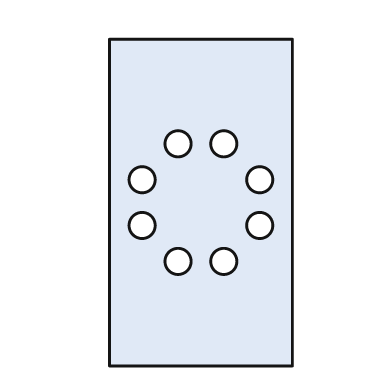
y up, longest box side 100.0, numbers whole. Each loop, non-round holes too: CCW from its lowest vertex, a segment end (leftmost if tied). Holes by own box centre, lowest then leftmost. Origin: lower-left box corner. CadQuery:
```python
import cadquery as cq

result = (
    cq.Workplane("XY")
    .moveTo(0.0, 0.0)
    .lineTo(56.0, 0.0)
    .lineTo(56.0, 100.0)
    .lineTo(0.0, 100.0)
    .close()
    .moveTo(21.0, 32.0)
    .circle(4.0)
    .moveTo(35.0, 32.0)
    .circle(4.0)
    .moveTo(10.0, 43.0)
    .circle(4.0)
    .moveTo(46.0, 43.0)
    .circle(4.0)
    .moveTo(10.0, 57.0)
    .circle(4.0)
    .moveTo(46.0, 57.0)
    .circle(4.0)
    .moveTo(21.0, 68.0)
    .circle(4.0)
    .moveTo(35.0, 68.0)
    .circle(4.0)
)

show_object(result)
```